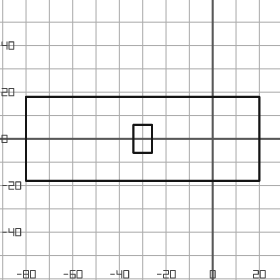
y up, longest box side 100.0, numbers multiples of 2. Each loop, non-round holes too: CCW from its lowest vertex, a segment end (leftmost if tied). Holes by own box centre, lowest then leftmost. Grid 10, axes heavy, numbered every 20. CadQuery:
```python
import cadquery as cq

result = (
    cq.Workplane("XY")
    .moveTo(-80.0, -18.0)
    .lineTo(20.0, -18.0)
    .lineTo(20.0, 18.0)
    .lineTo(-80.0, 18.0)
    .close()
    .moveTo(-34.0, -6.0)
    .lineTo(-26.0, -6.0)
    .lineTo(-26.0, 6.0)
    .lineTo(-34.0, 6.0)
    .close()
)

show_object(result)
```